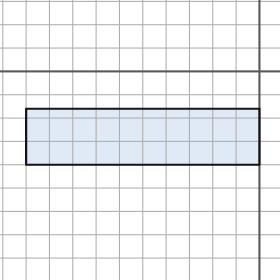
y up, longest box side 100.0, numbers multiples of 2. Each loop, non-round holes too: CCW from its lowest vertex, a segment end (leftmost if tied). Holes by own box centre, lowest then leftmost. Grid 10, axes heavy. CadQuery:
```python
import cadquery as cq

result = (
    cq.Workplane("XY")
    .moveTo(-100.0, -40.0)
    .lineTo(0.0, -40.0)
    .lineTo(0.0, -16.0)
    .lineTo(-100.0, -16.0)
    .close()
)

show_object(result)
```